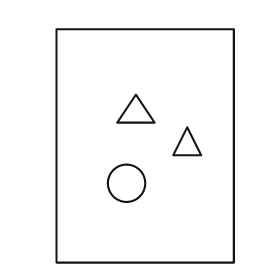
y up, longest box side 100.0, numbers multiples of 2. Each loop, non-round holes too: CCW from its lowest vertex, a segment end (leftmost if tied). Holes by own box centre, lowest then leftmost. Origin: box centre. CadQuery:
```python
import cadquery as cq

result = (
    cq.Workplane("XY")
    .moveTo(-38.0, -50.0)
    .lineTo(38.0, -50.0)
    .lineTo(38.0, 50.0)
    .lineTo(-38.0, 50.0)
    .close()
    .moveTo(-8.0, -16.0)
    .circle(8.0)
    .moveTo(12.0, -4.0)
    .lineTo(24.0, -4.0)
    .lineTo(18.0, 8.0)
    .close()
    .moveTo(-12.0, 10.0)
    .lineTo(4.0, 10.0)
    .lineTo(-4.0, 22.0)
    .close()
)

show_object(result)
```